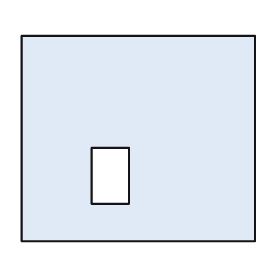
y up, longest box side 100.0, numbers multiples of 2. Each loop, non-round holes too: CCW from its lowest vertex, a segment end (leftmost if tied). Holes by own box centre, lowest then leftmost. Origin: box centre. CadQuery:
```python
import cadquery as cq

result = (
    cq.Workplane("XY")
    .moveTo(-50.0, -44.0)
    .lineTo(50.0, -44.0)
    .lineTo(50.0, 44.0)
    .lineTo(-50.0, 44.0)
    .close()
    .moveTo(-20.0, -28.0)
    .lineTo(-4.0, -28.0)
    .lineTo(-4.0, -4.0)
    .lineTo(-20.0, -4.0)
    .close()
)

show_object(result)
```